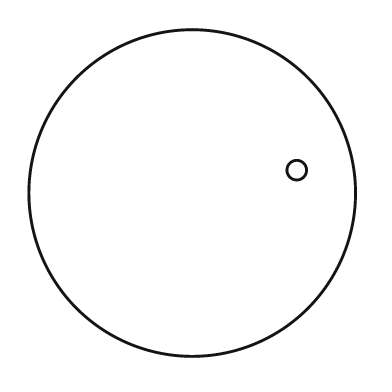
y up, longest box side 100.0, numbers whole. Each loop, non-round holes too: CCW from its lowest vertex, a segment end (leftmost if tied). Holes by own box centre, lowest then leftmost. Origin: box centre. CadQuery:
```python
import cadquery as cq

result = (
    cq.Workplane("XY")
    .moveTo(0.0, 0.0)
    .circle(50.0)
    .moveTo(32.0, 7.0)
    .circle(3.0)
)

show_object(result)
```